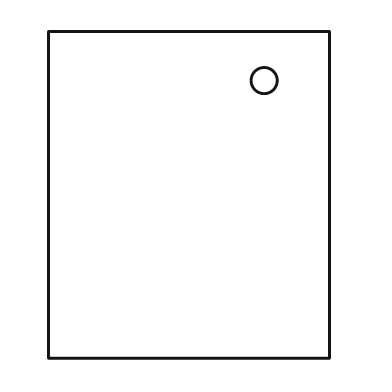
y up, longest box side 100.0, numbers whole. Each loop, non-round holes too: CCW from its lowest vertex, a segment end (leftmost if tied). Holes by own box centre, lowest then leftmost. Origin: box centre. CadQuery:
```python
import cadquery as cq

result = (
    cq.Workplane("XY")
    .moveTo(-43.0, -50.0)
    .lineTo(43.0, -50.0)
    .lineTo(43.0, 50.0)
    .lineTo(-43.0, 50.0)
    .close()
    .moveTo(23.0, 35.0)
    .circle(4.0)
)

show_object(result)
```